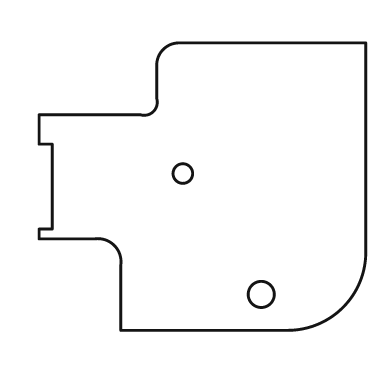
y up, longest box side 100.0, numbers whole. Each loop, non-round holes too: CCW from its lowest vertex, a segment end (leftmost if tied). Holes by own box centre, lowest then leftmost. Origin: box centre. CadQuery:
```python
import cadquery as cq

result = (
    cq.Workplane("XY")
    .moveTo(-25.0, -44.0)
    .lineTo(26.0, -44.0)
    .threePointArc((43.0, -37.0), (50.0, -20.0))
    .lineTo(50.0, 44.0)
    .lineTo(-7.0, 44.0)
    .threePointArc((-12.0, 42.0), (-14.0, 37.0))
    .lineTo(-14.0, 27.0)
    .threePointArc((-15.0, 23.0), (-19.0, 22.0))
    .lineTo(-50.0, 22.0)
    .lineTo(-50.0, 13.0)
    .lineTo(-46.0, 13.0)
    .lineTo(-46.0, -13.0)
    .lineTo(-50.0, -13.0)
    .lineTo(-50.0, -16.0)
    .lineTo(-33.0, -16.0)
    .threePointArc((-27.0, -18.0), (-25.0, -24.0))
    .close()
    .moveTo(18.0, -33.0)
    .circle(4.0)
    .moveTo(-6.0, 4.0)
    .circle(3.0)
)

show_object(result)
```